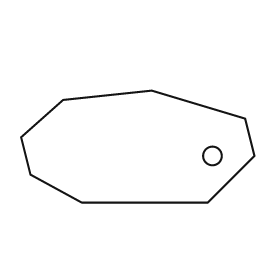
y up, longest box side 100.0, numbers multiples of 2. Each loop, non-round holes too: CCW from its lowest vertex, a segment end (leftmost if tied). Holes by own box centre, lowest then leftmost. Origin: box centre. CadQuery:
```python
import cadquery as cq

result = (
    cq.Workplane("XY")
    .moveTo(-24.0, -24.0)
    .lineTo(30.0, -24.0)
    .lineTo(50.0, -4.0)
    .lineTo(46.0, 12.0)
    .lineTo(6.0, 24.0)
    .lineTo(-32.0, 20.0)
    .lineTo(-50.0, 4.0)
    .lineTo(-46.0, -12.0)
    .close()
    .moveTo(32.0, -4.0)
    .circle(4.0)
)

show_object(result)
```